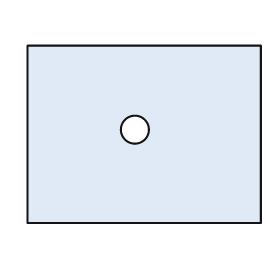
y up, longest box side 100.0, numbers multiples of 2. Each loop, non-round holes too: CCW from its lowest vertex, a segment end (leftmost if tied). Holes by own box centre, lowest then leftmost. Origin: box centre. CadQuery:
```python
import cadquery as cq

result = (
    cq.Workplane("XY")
    .moveTo(-50.0, -38.0)
    .lineTo(50.0, -38.0)
    .lineTo(50.0, 38.0)
    .lineTo(-50.0, 38.0)
    .close()
    .moveTo(-4.0, 2.0)
    .circle(6.0)
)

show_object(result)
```